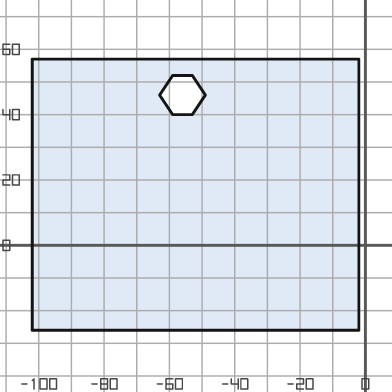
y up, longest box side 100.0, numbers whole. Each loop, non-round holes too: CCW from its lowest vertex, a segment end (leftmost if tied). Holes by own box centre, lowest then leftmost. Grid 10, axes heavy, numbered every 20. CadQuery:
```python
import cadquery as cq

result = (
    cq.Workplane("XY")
    .moveTo(-102.0, -26.0)
    .lineTo(-2.0, -26.0)
    .lineTo(-2.0, 57.0)
    .lineTo(-102.0, 57.0)
    .close()
    .moveTo(-59.0, 40.0)
    .lineTo(-53.0, 40.0)
    .lineTo(-49.0, 46.0)
    .lineTo(-53.0, 52.0)
    .lineTo(-59.0, 52.0)
    .lineTo(-63.0, 46.0)
    .close()
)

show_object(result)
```